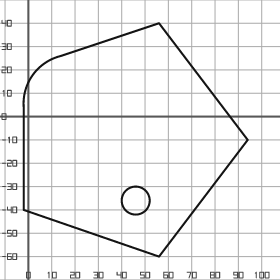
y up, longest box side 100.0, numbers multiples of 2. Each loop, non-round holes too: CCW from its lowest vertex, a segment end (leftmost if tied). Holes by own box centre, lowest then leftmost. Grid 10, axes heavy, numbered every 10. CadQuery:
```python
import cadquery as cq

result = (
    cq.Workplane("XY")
    .moveTo(56.0, -60.0)
    .lineTo(94.0, -10.0)
    .lineTo(56.0, 40.0)
    .lineTo(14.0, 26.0)
    .threePointArc((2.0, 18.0), (-2.0, 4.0))
    .lineTo(-2.0, -40.0)
    .close()
    .moveTo(46.0, -36.0)
    .circle(6.0)
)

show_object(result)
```